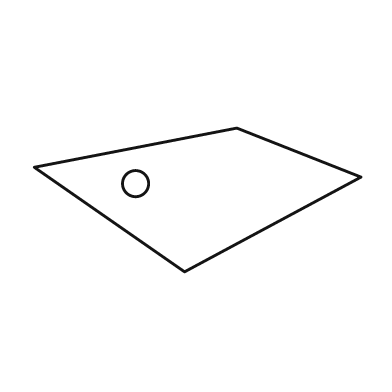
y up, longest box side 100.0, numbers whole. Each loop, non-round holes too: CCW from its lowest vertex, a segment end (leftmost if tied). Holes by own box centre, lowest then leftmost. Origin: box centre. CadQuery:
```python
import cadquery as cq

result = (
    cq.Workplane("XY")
    .moveTo(-4.0, -22.0)
    .lineTo(50.0, 7.0)
    .lineTo(12.0, 22.0)
    .lineTo(-50.0, 10.0)
    .close()
    .moveTo(-19.0, 5.0)
    .circle(4.0)
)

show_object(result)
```